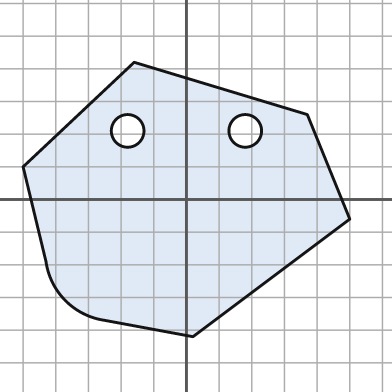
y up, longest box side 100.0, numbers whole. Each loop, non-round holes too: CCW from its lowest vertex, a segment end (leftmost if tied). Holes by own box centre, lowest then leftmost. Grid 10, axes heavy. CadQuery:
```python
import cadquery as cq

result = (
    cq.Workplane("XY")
    .moveTo(2.0, -42.0)
    .lineTo(50.0, -6.0)
    .lineTo(37.0, 26.0)
    .lineTo(-16.0, 42.0)
    .lineTo(-50.0, 10.0)
    .lineTo(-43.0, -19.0)
    .threePointArc((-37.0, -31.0), (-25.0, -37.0))
    .close()
    .moveTo(-18.0, 21.0)
    .circle(5.0)
    .moveTo(18.0, 21.0)
    .circle(5.0)
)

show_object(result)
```